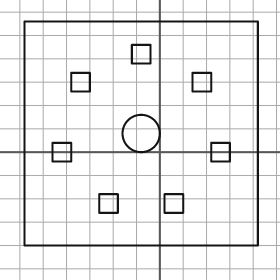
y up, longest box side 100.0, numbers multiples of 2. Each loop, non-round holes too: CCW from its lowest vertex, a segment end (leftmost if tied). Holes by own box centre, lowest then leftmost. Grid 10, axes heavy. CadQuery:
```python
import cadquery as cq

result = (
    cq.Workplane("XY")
    .moveTo(-58.0, -40.0)
    .lineTo(42.0, -40.0)
    .lineTo(42.0, 56.0)
    .lineTo(-58.0, 56.0)
    .close()
    .moveTo(-26.0, -26.0)
    .lineTo(-18.0, -26.0)
    .lineTo(-18.0, -18.0)
    .lineTo(-26.0, -18.0)
    .close()
    .moveTo(2.0, -26.0)
    .lineTo(10.0, -26.0)
    .lineTo(10.0, -18.0)
    .lineTo(2.0, -18.0)
    .close()
    .moveTo(-46.0, -4.0)
    .lineTo(-38.0, -4.0)
    .lineTo(-38.0, 4.0)
    .lineTo(-46.0, 4.0)
    .close()
    .moveTo(22.0, -4.0)
    .lineTo(30.0, -4.0)
    .lineTo(30.0, 4.0)
    .lineTo(22.0, 4.0)
    .close()
    .moveTo(-8.0, 8.0)
    .circle(8.0)
    .moveTo(-38.0, 26.0)
    .lineTo(-30.0, 26.0)
    .lineTo(-30.0, 34.0)
    .lineTo(-38.0, 34.0)
    .close()
    .moveTo(14.0, 26.0)
    .lineTo(22.0, 26.0)
    .lineTo(22.0, 34.0)
    .lineTo(14.0, 34.0)
    .close()
    .moveTo(-12.0, 38.0)
    .lineTo(-4.0, 38.0)
    .lineTo(-4.0, 46.0)
    .lineTo(-12.0, 46.0)
    .close()
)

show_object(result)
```